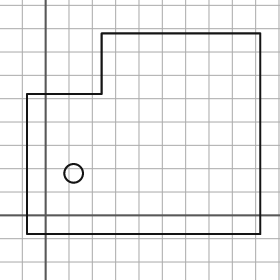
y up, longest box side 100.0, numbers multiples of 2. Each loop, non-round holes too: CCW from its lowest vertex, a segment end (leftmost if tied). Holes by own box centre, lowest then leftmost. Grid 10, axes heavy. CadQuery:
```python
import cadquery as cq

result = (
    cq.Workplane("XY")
    .moveTo(-8.0, -8.0)
    .lineTo(92.0, -8.0)
    .lineTo(92.0, 78.0)
    .lineTo(24.0, 78.0)
    .lineTo(24.0, 52.0)
    .lineTo(-8.0, 52.0)
    .close()
    .moveTo(12.0, 18.0)
    .circle(4.0)
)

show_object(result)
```